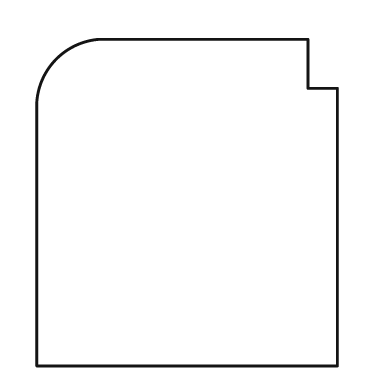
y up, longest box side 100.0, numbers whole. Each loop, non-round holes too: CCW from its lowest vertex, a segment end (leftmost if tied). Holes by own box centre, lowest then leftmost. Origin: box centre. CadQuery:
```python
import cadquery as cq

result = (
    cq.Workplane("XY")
    .moveTo(-46.0, -50.0)
    .lineTo(46.0, -50.0)
    .lineTo(46.0, 35.0)
    .lineTo(37.0, 35.0)
    .lineTo(37.0, 50.0)
    .lineTo(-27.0, 50.0)
    .threePointArc((-40.0, 44.0), (-46.0, 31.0))
    .close()
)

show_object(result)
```